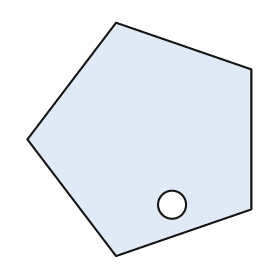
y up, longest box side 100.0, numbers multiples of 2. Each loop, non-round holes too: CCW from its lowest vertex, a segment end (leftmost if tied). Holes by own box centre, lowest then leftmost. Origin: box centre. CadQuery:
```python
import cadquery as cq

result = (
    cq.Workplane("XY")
    .moveTo(-10.0, -50.0)
    .lineTo(48.0, -30.0)
    .lineTo(48.0, 30.0)
    .lineTo(-10.0, 50.0)
    .lineTo(-48.0, 0.0)
    .close()
    .moveTo(14.0, -28.0)
    .circle(6.0)
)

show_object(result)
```